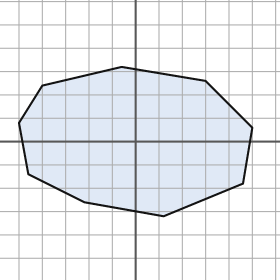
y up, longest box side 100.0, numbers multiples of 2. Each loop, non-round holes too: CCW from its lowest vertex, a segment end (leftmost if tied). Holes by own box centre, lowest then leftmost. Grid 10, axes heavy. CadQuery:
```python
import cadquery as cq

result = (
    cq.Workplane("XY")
    .moveTo(12.0, -32.0)
    .lineTo(46.0, -18.0)
    .lineTo(50.0, 6.0)
    .lineTo(30.0, 26.0)
    .lineTo(-6.0, 32.0)
    .lineTo(-40.0, 24.0)
    .lineTo(-50.0, 8.0)
    .lineTo(-46.0, -14.0)
    .lineTo(-22.0, -26.0)
    .close()
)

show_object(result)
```